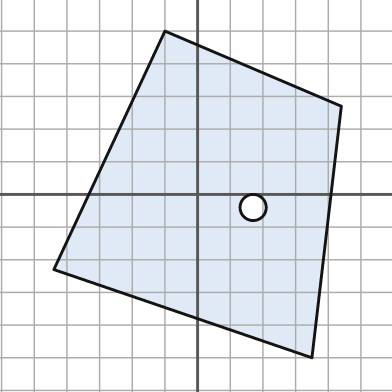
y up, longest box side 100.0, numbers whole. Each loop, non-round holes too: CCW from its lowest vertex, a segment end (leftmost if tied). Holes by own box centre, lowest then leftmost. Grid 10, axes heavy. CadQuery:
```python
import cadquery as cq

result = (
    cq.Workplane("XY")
    .moveTo(35.0, -50.0)
    .lineTo(44.0, 27.0)
    .lineTo(-10.0, 50.0)
    .lineTo(-44.0, -23.0)
    .close()
    .moveTo(17.0, -4.0)
    .circle(4.0)
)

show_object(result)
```